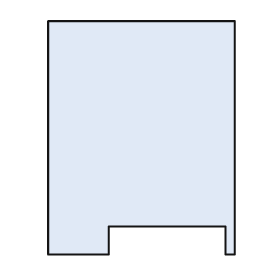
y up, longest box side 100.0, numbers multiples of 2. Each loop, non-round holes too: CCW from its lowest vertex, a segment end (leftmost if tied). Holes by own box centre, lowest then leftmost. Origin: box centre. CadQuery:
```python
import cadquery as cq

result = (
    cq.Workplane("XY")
    .moveTo(-40.0, -50.0)
    .lineTo(-14.0, -50.0)
    .lineTo(-14.0, -38.0)
    .lineTo(36.0, -38.0)
    .lineTo(36.0, -50.0)
    .lineTo(40.0, -50.0)
    .lineTo(40.0, 50.0)
    .lineTo(-40.0, 50.0)
    .close()
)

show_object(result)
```